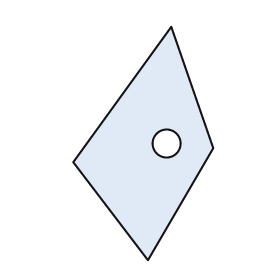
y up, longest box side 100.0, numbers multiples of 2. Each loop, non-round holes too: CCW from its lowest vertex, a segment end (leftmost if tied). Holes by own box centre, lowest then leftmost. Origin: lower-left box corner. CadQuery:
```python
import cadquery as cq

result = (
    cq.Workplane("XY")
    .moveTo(32.0, 0.0)
    .lineTo(60.0, 48.0)
    .lineTo(42.0, 100.0)
    .lineTo(0.0, 42.0)
    .close()
    .moveTo(40.0, 50.0)
    .circle(6.0)
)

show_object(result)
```